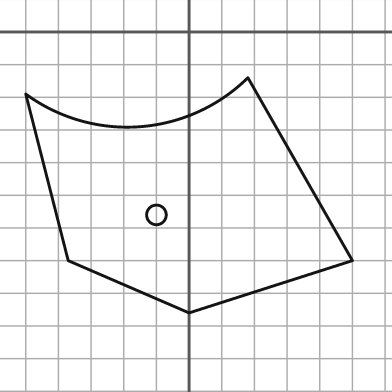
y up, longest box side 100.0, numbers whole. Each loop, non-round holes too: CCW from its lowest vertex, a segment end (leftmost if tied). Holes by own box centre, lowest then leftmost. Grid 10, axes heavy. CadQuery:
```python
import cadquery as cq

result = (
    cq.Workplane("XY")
    .moveTo(0.0, -86.0)
    .lineTo(50.0, -70.0)
    .lineTo(18.0, -14.0)
    .threePointArc((-15.0, -29.0), (-50.0, -19.0))
    .lineTo(-37.0, -70.0)
    .close()
    .moveTo(-10.0, -56.0)
    .circle(3.0)
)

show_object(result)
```